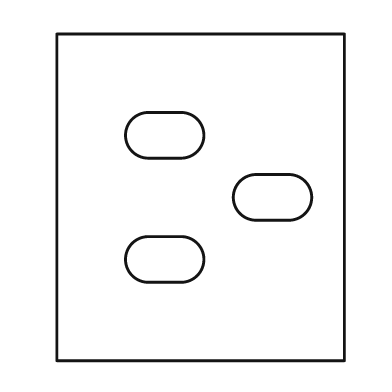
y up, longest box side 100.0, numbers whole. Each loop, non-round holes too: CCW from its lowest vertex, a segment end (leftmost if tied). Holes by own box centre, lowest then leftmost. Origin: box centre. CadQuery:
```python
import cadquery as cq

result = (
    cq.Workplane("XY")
    .moveTo(-44.0, -50.0)
    .lineTo(44.0, -50.0)
    .lineTo(44.0, 50.0)
    .lineTo(-44.0, 50.0)
    .close()
    .moveTo(-16.0, -26.0)
    .lineTo(-6.0, -26.0)
    .threePointArc((1.0, -19.0), (-6.0, -12.0))
    .lineTo(-16.0, -12.0)
    .threePointArc((-23.0, -19.0), (-16.0, -26.0))
    .close()
    .moveTo(17.0, -7.0)
    .lineTo(27.0, -7.0)
    .threePointArc((34.0, 0.0), (27.0, 7.0))
    .lineTo(17.0, 7.0)
    .threePointArc((10.0, 0.0), (17.0, -7.0))
    .close()
    .moveTo(-16.0, 12.0)
    .lineTo(-6.0, 12.0)
    .threePointArc((1.0, 19.0), (-6.0, 26.0))
    .lineTo(-16.0, 26.0)
    .threePointArc((-23.0, 19.0), (-16.0, 12.0))
    .close()
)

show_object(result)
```